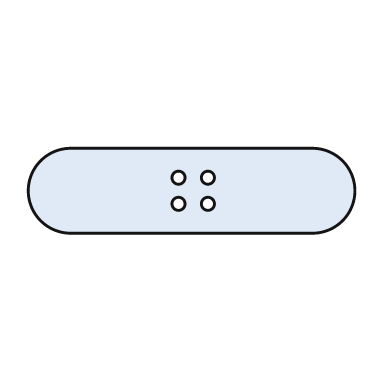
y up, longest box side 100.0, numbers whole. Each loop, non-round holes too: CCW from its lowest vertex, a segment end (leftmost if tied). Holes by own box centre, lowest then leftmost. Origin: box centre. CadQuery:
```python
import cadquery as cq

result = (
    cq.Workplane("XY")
    .moveTo(-37.0, -13.0)
    .lineTo(37.0, -13.0)
    .threePointArc((50.0, 0.0), (37.0, 13.0))
    .lineTo(-37.0, 13.0)
    .threePointArc((-50.0, 0.0), (-37.0, -13.0))
    .close()
    .moveTo(-4.0, -4.0)
    .circle(2.0)
    .moveTo(5.0, -4.0)
    .circle(2.0)
    .moveTo(-4.0, 4.0)
    .circle(2.0)
    .moveTo(5.0, 4.0)
    .circle(2.0)
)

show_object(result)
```